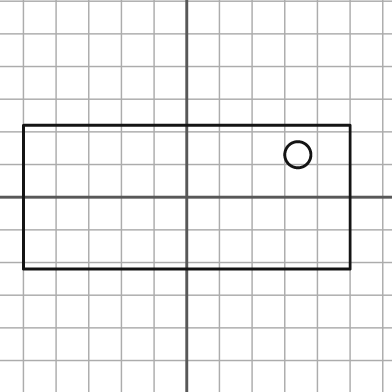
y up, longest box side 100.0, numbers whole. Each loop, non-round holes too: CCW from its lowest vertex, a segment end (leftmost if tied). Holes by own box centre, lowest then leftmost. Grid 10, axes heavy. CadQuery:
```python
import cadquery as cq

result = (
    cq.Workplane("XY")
    .moveTo(-50.0, -22.0)
    .lineTo(50.0, -22.0)
    .lineTo(50.0, 22.0)
    .lineTo(-50.0, 22.0)
    .close()
    .moveTo(34.0, 13.0)
    .circle(4.0)
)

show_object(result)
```